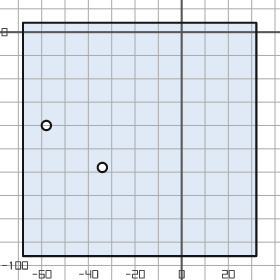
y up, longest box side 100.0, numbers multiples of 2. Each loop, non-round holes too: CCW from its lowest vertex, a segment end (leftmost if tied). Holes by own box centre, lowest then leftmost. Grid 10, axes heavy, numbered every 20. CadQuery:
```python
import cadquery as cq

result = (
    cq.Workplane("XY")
    .moveTo(-68.0, -96.0)
    .lineTo(32.0, -96.0)
    .lineTo(32.0, 4.0)
    .lineTo(-68.0, 4.0)
    .close()
    .moveTo(-34.0, -58.0)
    .circle(2.0)
    .moveTo(-58.0, -40.0)
    .circle(2.0)
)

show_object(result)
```